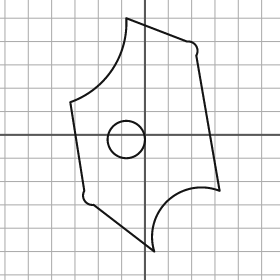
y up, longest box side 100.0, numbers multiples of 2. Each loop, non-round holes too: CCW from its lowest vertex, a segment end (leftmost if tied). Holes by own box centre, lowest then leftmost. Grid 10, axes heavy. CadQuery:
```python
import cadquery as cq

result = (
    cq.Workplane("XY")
    .moveTo(4.0, -50.0)
    .threePointArc((10.0, -28.0), (32.0, -24.0))
    .lineTo(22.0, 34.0)
    .threePointArc((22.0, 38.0), (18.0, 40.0))
    .lineTo(-8.0, 50.0)
    .threePointArc((-14.0, 28.0), (-32.0, 14.0))
    .lineTo(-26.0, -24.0)
    .threePointArc((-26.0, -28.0), (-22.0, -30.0))
    .close()
    .moveTo(-8.0, -2.0)
    .circle(8.0)
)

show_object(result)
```